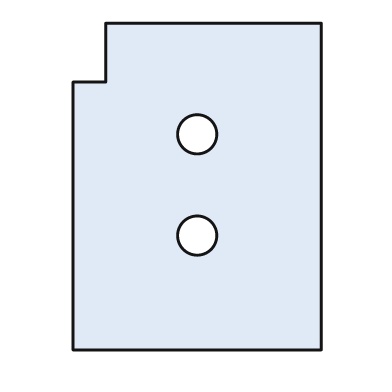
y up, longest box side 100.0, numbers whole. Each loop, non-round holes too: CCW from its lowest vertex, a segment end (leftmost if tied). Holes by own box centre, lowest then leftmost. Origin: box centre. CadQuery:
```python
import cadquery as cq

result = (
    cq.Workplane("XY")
    .moveTo(-38.0, -50.0)
    .lineTo(38.0, -50.0)
    .lineTo(38.0, 50.0)
    .lineTo(-28.0, 50.0)
    .lineTo(-28.0, 32.0)
    .lineTo(-38.0, 32.0)
    .close()
    .moveTo(0.0, -15.0)
    .circle(6.0)
    .moveTo(0.0, 16.0)
    .circle(6.0)
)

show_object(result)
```